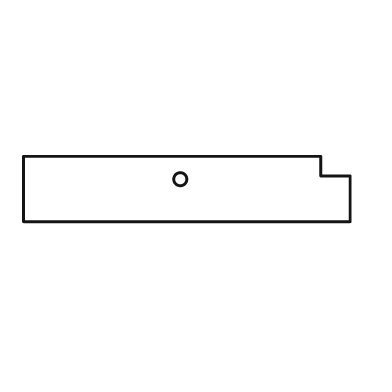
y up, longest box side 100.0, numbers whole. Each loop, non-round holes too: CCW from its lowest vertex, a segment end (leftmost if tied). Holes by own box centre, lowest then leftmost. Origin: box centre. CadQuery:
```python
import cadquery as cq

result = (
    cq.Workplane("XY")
    .moveTo(-50.0, -10.0)
    .lineTo(50.0, -10.0)
    .lineTo(50.0, 4.0)
    .lineTo(41.0, 4.0)
    .lineTo(41.0, 10.0)
    .lineTo(-50.0, 10.0)
    .close()
    .moveTo(-2.0, 3.0)
    .circle(2.0)
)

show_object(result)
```